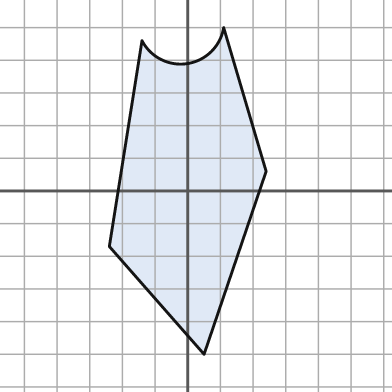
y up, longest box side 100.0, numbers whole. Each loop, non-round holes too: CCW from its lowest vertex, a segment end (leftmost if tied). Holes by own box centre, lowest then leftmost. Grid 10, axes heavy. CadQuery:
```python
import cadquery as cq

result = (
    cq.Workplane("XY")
    .moveTo(5.0, -50.0)
    .lineTo(24.0, 6.0)
    .lineTo(11.0, 50.0)
    .threePointArc((0.0, 39.0), (-14.0, 46.0))
    .lineTo(-24.0, -17.0)
    .close()
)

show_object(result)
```